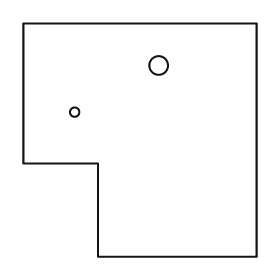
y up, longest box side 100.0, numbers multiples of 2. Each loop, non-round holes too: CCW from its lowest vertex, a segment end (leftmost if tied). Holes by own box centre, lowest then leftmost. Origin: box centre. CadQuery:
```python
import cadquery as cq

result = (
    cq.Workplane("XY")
    .moveTo(-18.0, -50.0)
    .lineTo(50.0, -50.0)
    .lineTo(50.0, 50.0)
    .lineTo(-50.0, 50.0)
    .lineTo(-50.0, -10.0)
    .lineTo(-18.0, -10.0)
    .close()
    .moveTo(-28.0, 12.0)
    .circle(2.0)
    .moveTo(8.0, 32.0)
    .circle(4.0)
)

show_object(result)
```